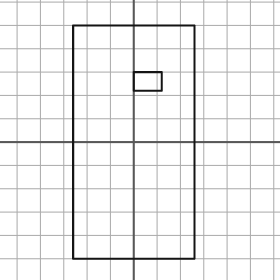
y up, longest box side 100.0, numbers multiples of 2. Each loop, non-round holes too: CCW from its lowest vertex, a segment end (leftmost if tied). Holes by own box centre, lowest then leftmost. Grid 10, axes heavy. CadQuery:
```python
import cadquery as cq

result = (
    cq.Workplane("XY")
    .moveTo(-26.0, -50.0)
    .lineTo(26.0, -50.0)
    .lineTo(26.0, 50.0)
    .lineTo(-26.0, 50.0)
    .close()
    .moveTo(0.0, 22.0)
    .lineTo(12.0, 22.0)
    .lineTo(12.0, 30.0)
    .lineTo(0.0, 30.0)
    .close()
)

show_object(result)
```